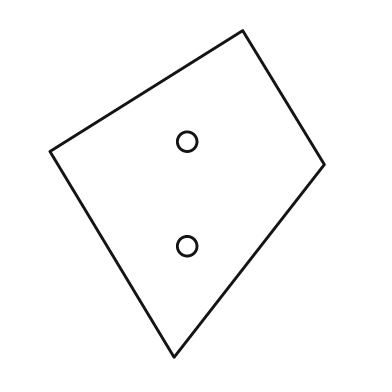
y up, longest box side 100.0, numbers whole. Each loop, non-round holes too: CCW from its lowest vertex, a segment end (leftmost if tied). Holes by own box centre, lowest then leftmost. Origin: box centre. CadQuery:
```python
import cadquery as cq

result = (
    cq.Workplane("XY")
    .moveTo(-4.0, -50.0)
    .lineTo(42.0, 9.0)
    .lineTo(17.0, 50.0)
    .lineTo(-42.0, 13.0)
    .close()
    .moveTo(0.0, -16.0)
    .circle(3.0)
    .moveTo(0.0, 16.0)
    .circle(3.0)
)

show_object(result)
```